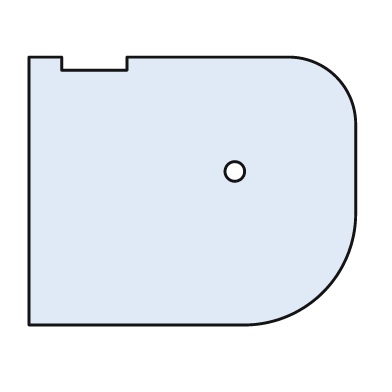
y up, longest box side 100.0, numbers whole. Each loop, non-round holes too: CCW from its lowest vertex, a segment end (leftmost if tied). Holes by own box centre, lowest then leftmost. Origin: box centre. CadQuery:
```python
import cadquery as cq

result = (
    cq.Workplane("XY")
    .moveTo(-50.0, -41.0)
    .lineTo(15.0, -41.0)
    .threePointArc((40.0, -31.0), (50.0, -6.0))
    .lineTo(50.0, 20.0)
    .threePointArc((44.0, 35.0), (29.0, 41.0))
    .lineTo(-20.0, 41.0)
    .lineTo(-20.0, 37.0)
    .lineTo(-40.0, 37.0)
    .lineTo(-40.0, 41.0)
    .lineTo(-50.0, 41.0)
    .close()
    .moveTo(13.0, 6.0)
    .circle(3.0)
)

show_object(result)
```